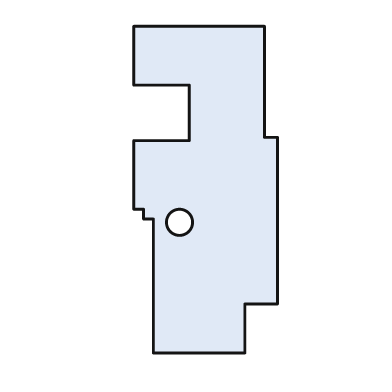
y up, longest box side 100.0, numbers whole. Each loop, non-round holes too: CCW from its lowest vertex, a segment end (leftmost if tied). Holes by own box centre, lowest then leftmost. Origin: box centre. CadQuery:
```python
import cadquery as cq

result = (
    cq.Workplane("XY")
    .moveTo(-16.0, -50.0)
    .lineTo(12.0, -50.0)
    .lineTo(12.0, -35.0)
    .lineTo(22.0, -35.0)
    .lineTo(22.0, 16.0)
    .lineTo(18.0, 16.0)
    .lineTo(18.0, 50.0)
    .lineTo(-22.0, 50.0)
    .lineTo(-22.0, 32.0)
    .lineTo(-5.0, 32.0)
    .lineTo(-5.0, 15.0)
    .lineTo(-22.0, 15.0)
    .lineTo(-22.0, -6.0)
    .lineTo(-19.0, -6.0)
    .lineTo(-19.0, -9.0)
    .lineTo(-16.0, -9.0)
    .close()
    .moveTo(-8.0, -10.0)
    .circle(4.0)
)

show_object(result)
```